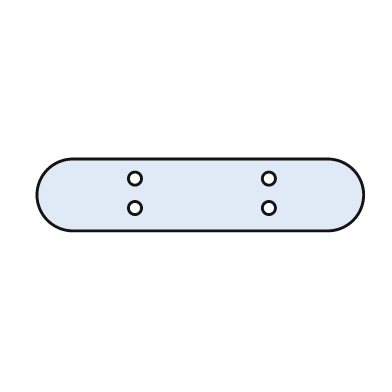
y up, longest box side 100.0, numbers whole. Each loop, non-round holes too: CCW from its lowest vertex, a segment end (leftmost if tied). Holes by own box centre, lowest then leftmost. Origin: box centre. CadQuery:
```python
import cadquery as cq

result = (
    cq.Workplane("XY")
    .moveTo(-39.0, -11.0)
    .lineTo(39.0, -11.0)
    .threePointArc((50.0, 0.0), (39.0, 11.0))
    .lineTo(-39.0, 11.0)
    .threePointArc((-50.0, 0.0), (-39.0, -11.0))
    .close()
    .moveTo(-20.0, -4.0)
    .circle(2.0)
    .moveTo(21.0, -4.0)
    .circle(2.0)
    .moveTo(-20.0, 5.0)
    .circle(2.0)
    .moveTo(21.0, 5.0)
    .circle(2.0)
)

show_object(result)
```